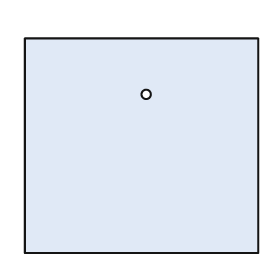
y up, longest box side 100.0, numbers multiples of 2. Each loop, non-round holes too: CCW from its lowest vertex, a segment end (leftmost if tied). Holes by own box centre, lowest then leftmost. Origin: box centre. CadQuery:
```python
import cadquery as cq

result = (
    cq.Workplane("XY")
    .moveTo(-50.0, -46.0)
    .lineTo(50.0, -46.0)
    .lineTo(50.0, 46.0)
    .lineTo(-50.0, 46.0)
    .close()
    .moveTo(2.0, 22.0)
    .circle(2.0)
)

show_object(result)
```